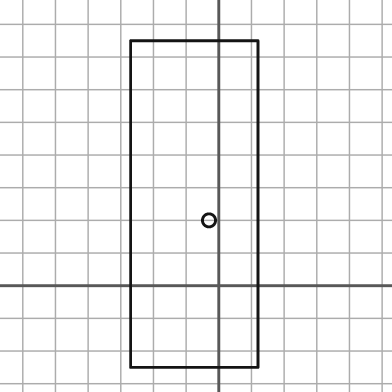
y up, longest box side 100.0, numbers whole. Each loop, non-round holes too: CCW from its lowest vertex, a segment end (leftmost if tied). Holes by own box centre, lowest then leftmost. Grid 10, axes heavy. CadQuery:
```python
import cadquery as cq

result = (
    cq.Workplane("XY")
    .moveTo(-27.0, -25.0)
    .lineTo(12.0, -25.0)
    .lineTo(12.0, 75.0)
    .lineTo(-27.0, 75.0)
    .close()
    .moveTo(-3.0, 20.0)
    .circle(2.0)
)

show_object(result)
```